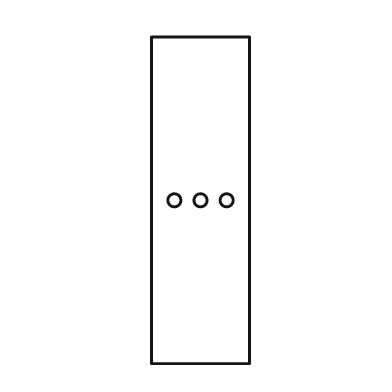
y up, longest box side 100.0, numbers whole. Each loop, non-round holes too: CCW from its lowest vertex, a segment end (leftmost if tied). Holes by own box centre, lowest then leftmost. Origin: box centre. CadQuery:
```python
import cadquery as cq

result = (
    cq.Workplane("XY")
    .moveTo(-15.0, -50.0)
    .lineTo(15.0, -50.0)
    .lineTo(15.0, 50.0)
    .lineTo(-15.0, 50.0)
    .close()
    .moveTo(-8.0, 0.0)
    .circle(2.0)
    .moveTo(0.0, 0.0)
    .circle(2.0)
    .moveTo(8.0, 0.0)
    .circle(2.0)
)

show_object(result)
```